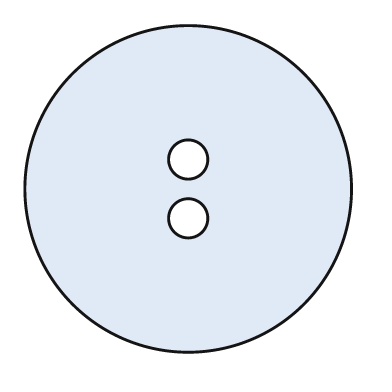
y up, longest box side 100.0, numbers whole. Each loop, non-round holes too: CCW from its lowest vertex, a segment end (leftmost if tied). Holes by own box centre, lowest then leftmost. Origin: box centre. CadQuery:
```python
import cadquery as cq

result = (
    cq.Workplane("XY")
    .moveTo(0.0, 0.0)
    .circle(50.0)
    .moveTo(0.0, -9.0)
    .circle(6.0)
    .moveTo(0.0, 9.0)
    .circle(6.0)
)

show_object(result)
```